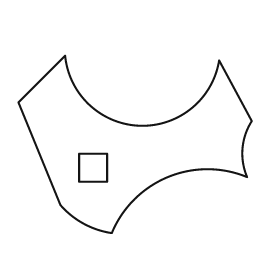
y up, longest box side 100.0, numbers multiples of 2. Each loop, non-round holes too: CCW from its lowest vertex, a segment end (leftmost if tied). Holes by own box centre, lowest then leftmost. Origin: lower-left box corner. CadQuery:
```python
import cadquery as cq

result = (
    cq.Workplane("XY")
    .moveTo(40.0, 0.0)
    .threePointArc((64.0, 24.0), (98.0, 24.0))
    .threePointArc((96.0, 36.0), (100.0, 48.0))
    .lineTo(86.0, 74.0)
    .threePointArc((52.0, 46.0), (20.0, 76.0))
    .lineTo(0.0, 56.0)
    .lineTo(18.0, 12.0)
    .threePointArc((28.0, 4.0), (40.0, 0.0))
    .close()
    .moveTo(26.0, 22.0)
    .lineTo(38.0, 22.0)
    .lineTo(38.0, 34.0)
    .lineTo(26.0, 34.0)
    .close()
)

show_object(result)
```